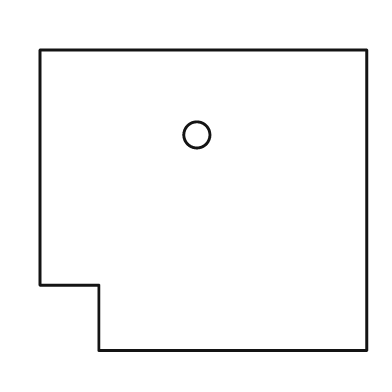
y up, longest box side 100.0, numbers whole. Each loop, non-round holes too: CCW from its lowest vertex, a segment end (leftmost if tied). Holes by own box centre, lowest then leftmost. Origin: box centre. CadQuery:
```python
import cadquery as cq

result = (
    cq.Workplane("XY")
    .moveTo(-32.0, -46.0)
    .lineTo(50.0, -46.0)
    .lineTo(50.0, 46.0)
    .lineTo(-50.0, 46.0)
    .lineTo(-50.0, -26.0)
    .lineTo(-32.0, -26.0)
    .close()
    .moveTo(-2.0, 20.0)
    .circle(4.0)
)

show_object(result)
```